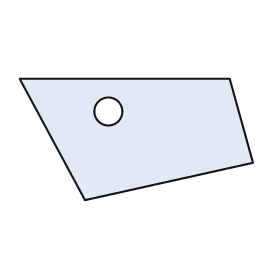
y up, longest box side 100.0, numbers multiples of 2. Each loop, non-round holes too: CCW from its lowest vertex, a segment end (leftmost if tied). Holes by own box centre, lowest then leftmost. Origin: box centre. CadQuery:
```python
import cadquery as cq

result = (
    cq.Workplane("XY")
    .moveTo(-22.0, -26.0)
    .lineTo(50.0, -10.0)
    .lineTo(40.0, 26.0)
    .lineTo(-50.0, 26.0)
    .close()
    .moveTo(-12.0, 12.0)
    .circle(6.0)
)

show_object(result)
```